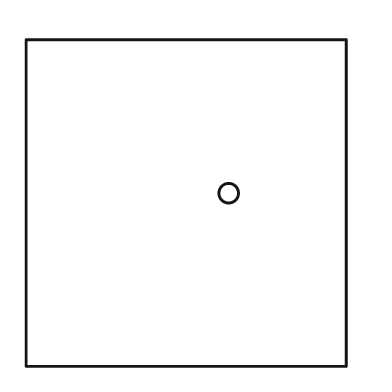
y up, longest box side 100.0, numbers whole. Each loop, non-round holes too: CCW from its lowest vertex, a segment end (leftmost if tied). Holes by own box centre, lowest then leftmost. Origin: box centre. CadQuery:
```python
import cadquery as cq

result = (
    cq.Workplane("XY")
    .moveTo(-49.0, -50.0)
    .lineTo(49.0, -50.0)
    .lineTo(49.0, 50.0)
    .lineTo(-49.0, 50.0)
    .close()
    .moveTo(13.0, 3.0)
    .circle(3.0)
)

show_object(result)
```